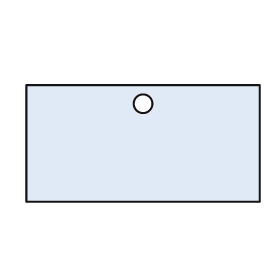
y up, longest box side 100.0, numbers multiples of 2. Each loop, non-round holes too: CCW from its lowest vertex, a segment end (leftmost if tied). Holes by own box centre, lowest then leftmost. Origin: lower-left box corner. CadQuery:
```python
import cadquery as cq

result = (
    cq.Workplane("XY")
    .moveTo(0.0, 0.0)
    .lineTo(100.0, 0.0)
    .lineTo(100.0, 50.0)
    .lineTo(0.0, 50.0)
    .close()
    .moveTo(50.0, 42.0)
    .circle(4.0)
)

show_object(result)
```